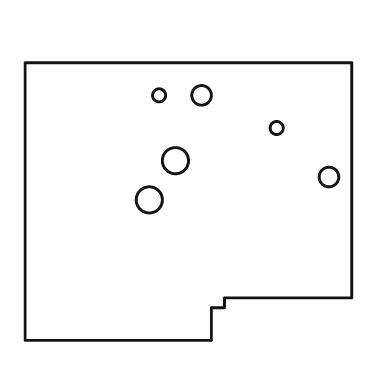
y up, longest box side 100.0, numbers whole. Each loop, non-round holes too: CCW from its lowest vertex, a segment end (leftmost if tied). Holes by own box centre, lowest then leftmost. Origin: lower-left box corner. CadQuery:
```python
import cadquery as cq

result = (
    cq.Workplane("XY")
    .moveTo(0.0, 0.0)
    .lineTo(57.0, 0.0)
    .lineTo(57.0, 10.0)
    .lineTo(61.0, 10.0)
    .lineTo(61.0, 13.0)
    .lineTo(100.0, 13.0)
    .lineTo(100.0, 85.0)
    .lineTo(0.0, 85.0)
    .close()
    .moveTo(38.0, 43.0)
    .circle(4.0)
    .moveTo(93.0, 50.0)
    .circle(3.0)
    .moveTo(46.0, 55.0)
    .circle(4.0)
    .moveTo(77.0, 65.0)
    .circle(2.0)
    .moveTo(41.0, 75.0)
    .circle(2.0)
    .moveTo(54.0, 75.0)
    .circle(3.0)
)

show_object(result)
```